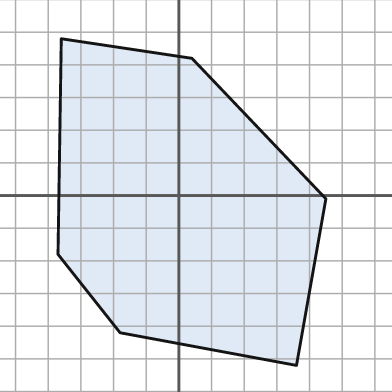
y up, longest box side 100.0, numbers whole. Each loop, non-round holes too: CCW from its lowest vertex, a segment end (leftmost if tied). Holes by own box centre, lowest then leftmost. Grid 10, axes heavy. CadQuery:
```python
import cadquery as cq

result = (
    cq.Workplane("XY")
    .moveTo(36.0, -52.0)
    .lineTo(45.0, -1.0)
    .lineTo(4.0, 42.0)
    .lineTo(-36.0, 48.0)
    .lineTo(-37.0, -18.0)
    .lineTo(-18.0, -42.0)
    .close()
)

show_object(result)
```